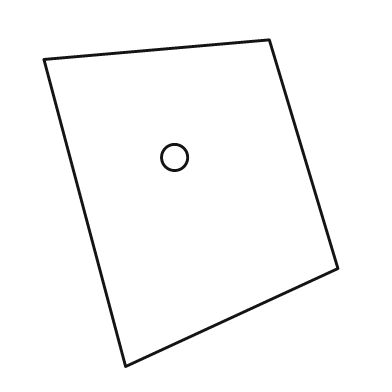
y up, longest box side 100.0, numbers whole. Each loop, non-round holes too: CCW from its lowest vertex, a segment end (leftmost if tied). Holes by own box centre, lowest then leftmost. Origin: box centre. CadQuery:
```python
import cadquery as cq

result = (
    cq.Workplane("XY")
    .moveTo(-20.0, -50.0)
    .lineTo(45.0, -20.0)
    .lineTo(24.0, 50.0)
    .lineTo(-45.0, 44.0)
    .close()
    .moveTo(-5.0, 14.0)
    .circle(4.0)
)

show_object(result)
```